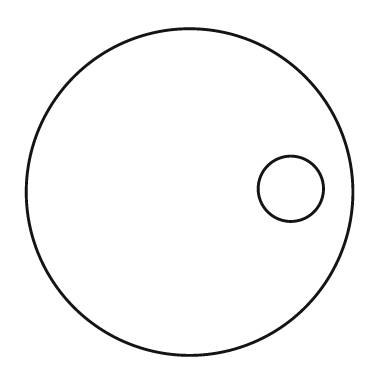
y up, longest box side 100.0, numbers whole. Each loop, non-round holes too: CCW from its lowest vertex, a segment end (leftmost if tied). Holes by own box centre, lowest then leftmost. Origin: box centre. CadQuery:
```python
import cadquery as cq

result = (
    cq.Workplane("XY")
    .moveTo(0.0, 0.0)
    .circle(50.0)
    .moveTo(31.0, 1.0)
    .circle(10.0)
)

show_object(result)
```